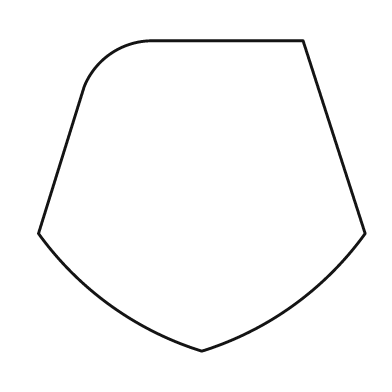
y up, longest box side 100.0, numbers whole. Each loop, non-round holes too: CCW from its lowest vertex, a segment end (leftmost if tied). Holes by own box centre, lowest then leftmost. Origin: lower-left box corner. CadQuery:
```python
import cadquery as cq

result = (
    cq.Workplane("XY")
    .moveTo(50.0, 0.0)
    .threePointArc((78.0, 14.0), (100.0, 36.0))
    .lineTo(81.0, 95.0)
    .lineTo(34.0, 95.0)
    .threePointArc((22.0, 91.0), (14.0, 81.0))
    .lineTo(0.0, 36.0)
    .threePointArc((22.0, 14.0), (50.0, 0.0))
    .close()
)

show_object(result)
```